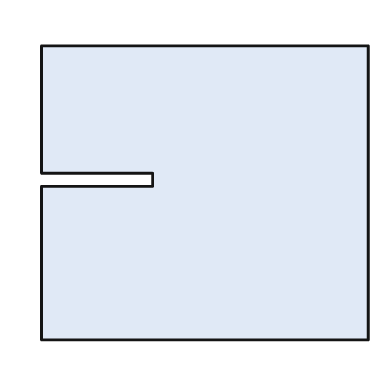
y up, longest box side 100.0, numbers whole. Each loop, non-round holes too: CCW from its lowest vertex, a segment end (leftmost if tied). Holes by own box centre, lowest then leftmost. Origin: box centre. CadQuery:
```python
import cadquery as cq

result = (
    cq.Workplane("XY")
    .moveTo(-50.0, -45.0)
    .lineTo(50.0, -45.0)
    .lineTo(50.0, 45.0)
    .lineTo(-50.0, 45.0)
    .lineTo(-50.0, 6.0)
    .lineTo(-16.0, 6.0)
    .lineTo(-16.0, 2.0)
    .lineTo(-50.0, 2.0)
    .close()
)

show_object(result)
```